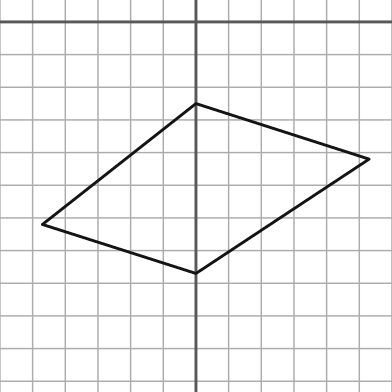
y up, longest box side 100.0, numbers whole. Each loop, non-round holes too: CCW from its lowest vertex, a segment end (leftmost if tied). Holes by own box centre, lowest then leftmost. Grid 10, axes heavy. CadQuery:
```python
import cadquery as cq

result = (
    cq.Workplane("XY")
    .moveTo(0.0, -77.0)
    .lineTo(53.0, -42.0)
    .lineTo(0.0, -25.0)
    .lineTo(-47.0, -62.0)
    .close()
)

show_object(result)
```